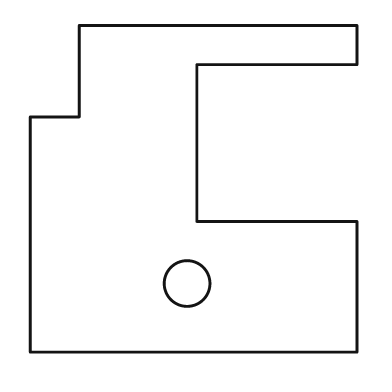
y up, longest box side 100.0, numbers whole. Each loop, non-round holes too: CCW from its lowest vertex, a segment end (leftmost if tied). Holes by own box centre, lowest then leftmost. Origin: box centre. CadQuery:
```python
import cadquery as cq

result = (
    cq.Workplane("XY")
    .moveTo(-50.0, -50.0)
    .lineTo(50.0, -50.0)
    .lineTo(50.0, -10.0)
    .lineTo(1.0, -10.0)
    .lineTo(1.0, 38.0)
    .lineTo(50.0, 38.0)
    .lineTo(50.0, 50.0)
    .lineTo(-35.0, 50.0)
    .lineTo(-35.0, 22.0)
    .lineTo(-50.0, 22.0)
    .close()
    .moveTo(-2.0, -29.0)
    .circle(7.0)
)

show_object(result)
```